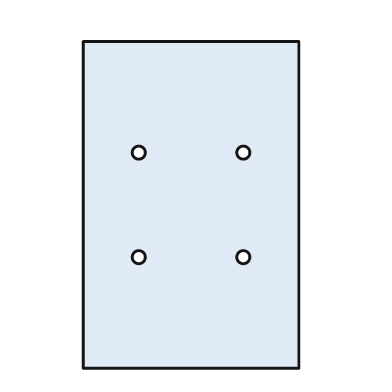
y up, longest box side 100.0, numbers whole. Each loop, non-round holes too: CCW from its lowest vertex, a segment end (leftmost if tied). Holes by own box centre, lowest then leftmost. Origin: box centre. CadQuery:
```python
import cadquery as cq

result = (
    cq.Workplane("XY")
    .moveTo(-33.0, -50.0)
    .lineTo(33.0, -50.0)
    .lineTo(33.0, 50.0)
    .lineTo(-33.0, 50.0)
    .close()
    .moveTo(-16.0, -16.0)
    .circle(2.0)
    .moveTo(16.0, -16.0)
    .circle(2.0)
    .moveTo(-16.0, 16.0)
    .circle(2.0)
    .moveTo(16.0, 16.0)
    .circle(2.0)
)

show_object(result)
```